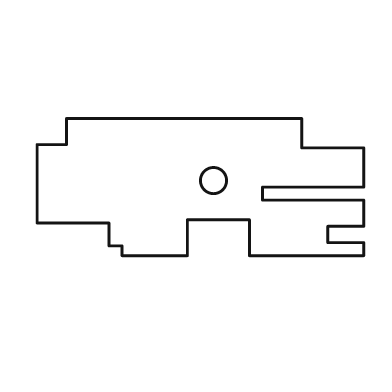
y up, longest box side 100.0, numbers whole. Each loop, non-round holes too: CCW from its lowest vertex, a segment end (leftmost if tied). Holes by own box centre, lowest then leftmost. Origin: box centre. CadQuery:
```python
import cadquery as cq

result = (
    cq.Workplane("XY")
    .moveTo(-24.0, -21.0)
    .lineTo(-4.0, -21.0)
    .lineTo(-4.0, -10.0)
    .lineTo(15.0, -10.0)
    .lineTo(15.0, -21.0)
    .lineTo(50.0, -21.0)
    .lineTo(50.0, -17.0)
    .lineTo(39.0, -17.0)
    .lineTo(39.0, -12.0)
    .lineTo(50.0, -12.0)
    .lineTo(50.0, -4.0)
    .lineTo(19.0, -4.0)
    .lineTo(19.0, 0.0)
    .lineTo(50.0, 0.0)
    .lineTo(50.0, 12.0)
    .lineTo(31.0, 12.0)
    .lineTo(31.0, 21.0)
    .lineTo(-41.0, 21.0)
    .lineTo(-41.0, 13.0)
    .lineTo(-50.0, 13.0)
    .lineTo(-50.0, -11.0)
    .lineTo(-28.0, -11.0)
    .lineTo(-28.0, -18.0)
    .lineTo(-24.0, -18.0)
    .close()
    .moveTo(4.0, 2.0)
    .circle(4.0)
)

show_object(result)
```